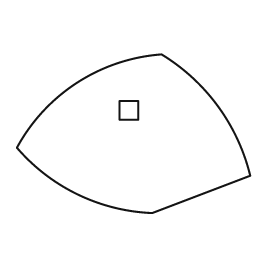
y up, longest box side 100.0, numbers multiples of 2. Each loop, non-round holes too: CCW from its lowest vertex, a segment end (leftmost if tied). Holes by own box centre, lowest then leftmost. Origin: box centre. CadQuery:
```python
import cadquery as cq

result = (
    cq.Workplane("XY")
    .moveTo(8.0, -34.0)
    .lineTo(50.0, -18.0)
    .threePointArc((36.0, 12.0), (12.0, 34.0))
    .threePointArc((-24.0, 22.0), (-50.0, -6.0))
    .threePointArc((-24.0, -26.0), (8.0, -34.0))
    .close()
    .moveTo(-6.0, 6.0)
    .lineTo(2.0, 6.0)
    .lineTo(2.0, 14.0)
    .lineTo(-6.0, 14.0)
    .close()
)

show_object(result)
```